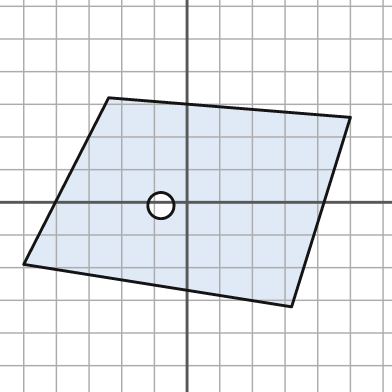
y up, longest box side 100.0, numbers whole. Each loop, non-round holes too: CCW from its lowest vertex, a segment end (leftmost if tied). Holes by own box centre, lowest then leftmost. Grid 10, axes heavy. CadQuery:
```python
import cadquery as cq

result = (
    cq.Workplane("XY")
    .moveTo(32.0, -32.0)
    .lineTo(50.0, 26.0)
    .lineTo(-24.0, 32.0)
    .lineTo(-50.0, -19.0)
    .close()
    .moveTo(-8.0, -1.0)
    .circle(4.0)
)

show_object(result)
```